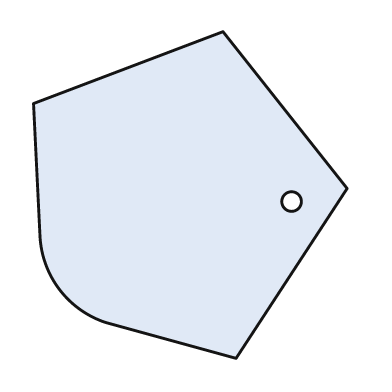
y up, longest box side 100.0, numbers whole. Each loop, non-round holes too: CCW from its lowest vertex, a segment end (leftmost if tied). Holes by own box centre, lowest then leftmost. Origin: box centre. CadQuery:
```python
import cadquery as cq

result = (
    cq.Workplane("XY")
    .moveTo(14.0, -50.0)
    .lineTo(48.0, 2.0)
    .lineTo(10.0, 50.0)
    .lineTo(-48.0, 28.0)
    .lineTo(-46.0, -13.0)
    .threePointArc((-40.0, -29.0), (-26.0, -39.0))
    .close()
    .moveTo(31.0, -2.0)
    .circle(3.0)
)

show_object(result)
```